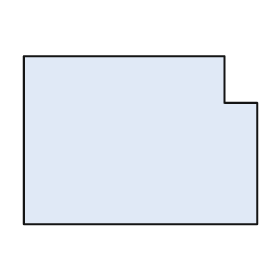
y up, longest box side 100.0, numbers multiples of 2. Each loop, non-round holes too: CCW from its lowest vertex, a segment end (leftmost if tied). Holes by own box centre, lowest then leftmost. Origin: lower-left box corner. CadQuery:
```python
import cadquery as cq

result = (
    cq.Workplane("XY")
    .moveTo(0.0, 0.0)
    .lineTo(100.0, 0.0)
    .lineTo(100.0, 52.0)
    .lineTo(86.0, 52.0)
    .lineTo(86.0, 72.0)
    .lineTo(0.0, 72.0)
    .close()
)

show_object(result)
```